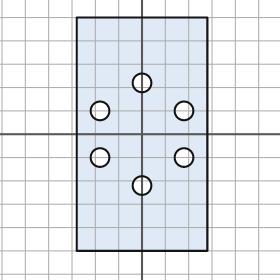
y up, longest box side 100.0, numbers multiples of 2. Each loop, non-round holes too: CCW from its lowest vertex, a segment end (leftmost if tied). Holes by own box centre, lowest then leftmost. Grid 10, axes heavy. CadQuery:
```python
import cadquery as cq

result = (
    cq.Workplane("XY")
    .moveTo(-28.0, -50.0)
    .lineTo(28.0, -50.0)
    .lineTo(28.0, 50.0)
    .lineTo(-28.0, 50.0)
    .close()
    .moveTo(0.0, -22.0)
    .circle(4.0)
    .moveTo(-18.0, -10.0)
    .circle(4.0)
    .moveTo(18.0, -10.0)
    .circle(4.0)
    .moveTo(-18.0, 10.0)
    .circle(4.0)
    .moveTo(18.0, 10.0)
    .circle(4.0)
    .moveTo(0.0, 22.0)
    .circle(4.0)
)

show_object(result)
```